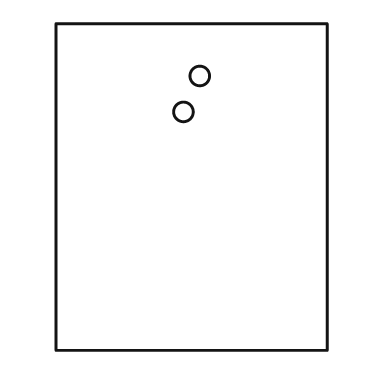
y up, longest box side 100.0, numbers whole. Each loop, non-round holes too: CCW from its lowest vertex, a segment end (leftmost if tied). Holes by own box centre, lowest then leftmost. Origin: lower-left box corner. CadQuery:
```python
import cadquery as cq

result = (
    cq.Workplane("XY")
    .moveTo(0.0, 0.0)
    .lineTo(83.0, 0.0)
    .lineTo(83.0, 100.0)
    .lineTo(0.0, 100.0)
    .close()
    .moveTo(39.0, 73.0)
    .circle(3.0)
    .moveTo(44.0, 84.0)
    .circle(3.0)
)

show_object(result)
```